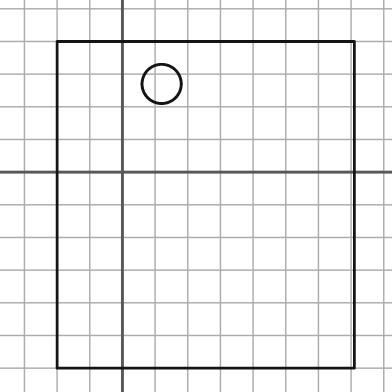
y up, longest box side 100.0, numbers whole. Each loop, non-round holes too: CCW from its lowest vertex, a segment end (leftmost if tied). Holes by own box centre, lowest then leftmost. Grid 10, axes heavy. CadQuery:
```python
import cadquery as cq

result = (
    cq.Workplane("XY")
    .moveTo(-20.0, -60.0)
    .lineTo(71.0, -60.0)
    .lineTo(71.0, 40.0)
    .lineTo(-20.0, 40.0)
    .close()
    .moveTo(12.0, 27.0)
    .circle(6.0)
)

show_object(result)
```